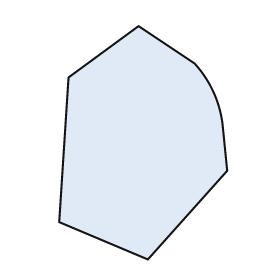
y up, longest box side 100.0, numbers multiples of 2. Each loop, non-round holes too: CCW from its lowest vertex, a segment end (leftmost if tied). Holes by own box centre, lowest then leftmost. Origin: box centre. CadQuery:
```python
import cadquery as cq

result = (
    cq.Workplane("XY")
    .moveTo(2.0, -50.0)
    .lineTo(36.0, -12.0)
    .lineTo(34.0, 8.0)
    .threePointArc((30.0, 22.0), (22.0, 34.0))
    .lineTo(-2.0, 50.0)
    .lineTo(-32.0, 28.0)
    .lineTo(-36.0, -34.0)
    .close()
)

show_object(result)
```